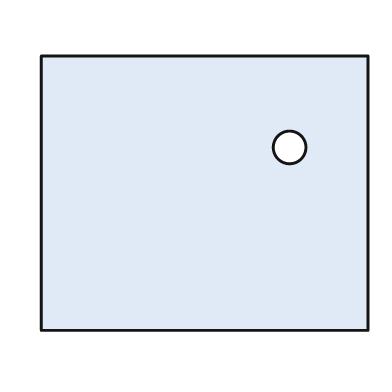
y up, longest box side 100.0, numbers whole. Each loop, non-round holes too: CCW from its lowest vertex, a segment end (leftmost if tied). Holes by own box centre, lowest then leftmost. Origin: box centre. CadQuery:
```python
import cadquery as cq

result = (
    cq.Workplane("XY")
    .moveTo(-50.0, -42.0)
    .lineTo(50.0, -42.0)
    .lineTo(50.0, 42.0)
    .lineTo(-50.0, 42.0)
    .close()
    .moveTo(26.0, 14.0)
    .circle(5.0)
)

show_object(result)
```